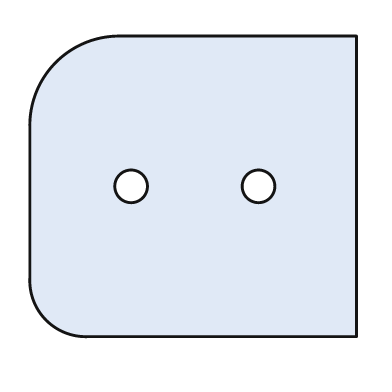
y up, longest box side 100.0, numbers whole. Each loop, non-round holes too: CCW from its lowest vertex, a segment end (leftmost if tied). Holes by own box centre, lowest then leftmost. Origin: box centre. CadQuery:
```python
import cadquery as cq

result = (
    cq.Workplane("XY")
    .moveTo(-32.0, -46.0)
    .lineTo(50.0, -46.0)
    .lineTo(50.0, 46.0)
    .lineTo(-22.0, 46.0)
    .threePointArc((-42.0, 38.0), (-50.0, 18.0))
    .lineTo(-50.0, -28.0)
    .threePointArc((-45.0, -41.0), (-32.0, -46.0))
    .close()
    .moveTo(-19.0, 0.0)
    .circle(5.0)
    .moveTo(20.0, 0.0)
    .circle(5.0)
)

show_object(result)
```